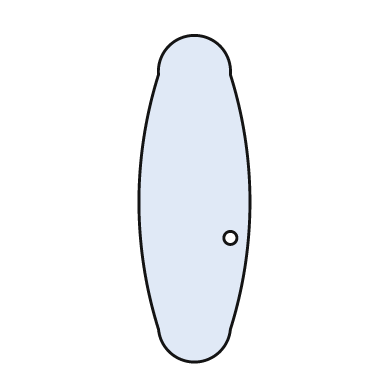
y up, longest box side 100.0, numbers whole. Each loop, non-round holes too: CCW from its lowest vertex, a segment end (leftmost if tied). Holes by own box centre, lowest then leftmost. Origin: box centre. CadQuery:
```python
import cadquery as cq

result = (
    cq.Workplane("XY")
    .moveTo(-11.0, -40.0)
    .threePointArc((0.0, -50.0), (11.0, -40.0))
    .threePointArc((17.0, -1.0), (11.0, 38.0))
    .threePointArc((0.0, 50.0), (-11.0, 38.0))
    .threePointArc((-17.0, -1.0), (-11.0, -40.0))
    .close()
    .moveTo(11.0, -12.0)
    .circle(2.0)
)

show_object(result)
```